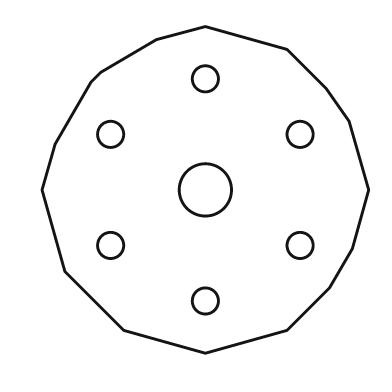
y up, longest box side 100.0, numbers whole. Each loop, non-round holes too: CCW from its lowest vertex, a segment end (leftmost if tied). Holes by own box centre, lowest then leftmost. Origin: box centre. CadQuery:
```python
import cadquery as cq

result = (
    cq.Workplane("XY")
    .moveTo(0.0, -50.0)
    .lineTo(25.0, -43.0)
    .lineTo(38.0, -30.0)
    .lineTo(45.0, -18.0)
    .lineTo(50.0, 0.0)
    .lineTo(44.0, 21.0)
    .lineTo(37.0, 31.0)
    .lineTo(25.0, 43.0)
    .lineTo(0.0, 50.0)
    .lineTo(-15.0, 46.0)
    .lineTo(-32.0, 36.0)
    .lineTo(-35.0, 33.0)
    .lineTo(-46.0, 14.0)
    .lineTo(-50.0, 0.0)
    .lineTo(-43.0, -25.0)
    .lineTo(-25.0, -43.0)
    .close()
    .moveTo(0.0, -34.0)
    .circle(4.0)
    .moveTo(-29.0, -17.0)
    .circle(4.0)
    .moveTo(29.0, -17.0)
    .circle(4.0)
    .moveTo(0.0, 0.0)
    .circle(8.0)
    .moveTo(-29.0, 17.0)
    .circle(4.0)
    .moveTo(29.0, 17.0)
    .circle(4.0)
    .moveTo(0.0, 34.0)
    .circle(4.0)
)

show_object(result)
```